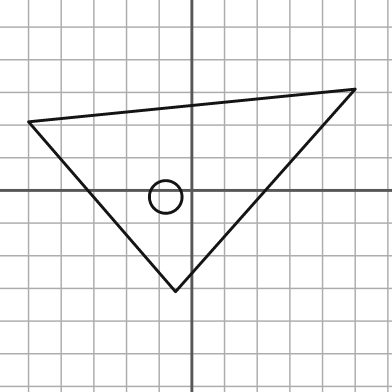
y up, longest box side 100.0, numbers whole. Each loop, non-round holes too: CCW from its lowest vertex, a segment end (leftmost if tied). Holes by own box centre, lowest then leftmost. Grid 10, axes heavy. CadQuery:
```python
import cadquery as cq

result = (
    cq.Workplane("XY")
    .moveTo(-5.0, -31.0)
    .lineTo(50.0, 31.0)
    .lineTo(-50.0, 21.0)
    .close()
    .moveTo(-8.0, -2.0)
    .circle(5.0)
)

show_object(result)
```